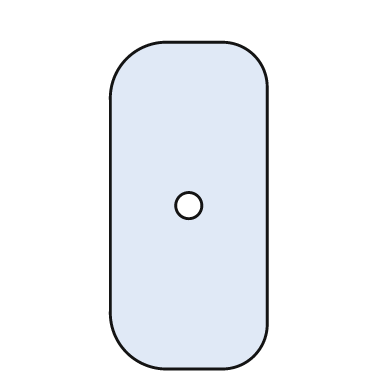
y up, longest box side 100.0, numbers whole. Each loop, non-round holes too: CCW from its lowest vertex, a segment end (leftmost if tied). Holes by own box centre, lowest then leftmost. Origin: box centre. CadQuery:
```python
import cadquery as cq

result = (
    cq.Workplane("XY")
    .moveTo(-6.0, -50.0)
    .lineTo(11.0, -50.0)
    .threePointArc((20.0, -46.0), (24.0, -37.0))
    .lineTo(24.0, 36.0)
    .threePointArc((20.0, 46.0), (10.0, 50.0))
    .lineTo(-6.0, 50.0)
    .threePointArc((-19.0, 45.0), (-24.0, 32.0))
    .lineTo(-24.0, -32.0)
    .threePointArc((-19.0, -45.0), (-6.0, -50.0))
    .close()
    .moveTo(0.0, 0.0)
    .circle(4.0)
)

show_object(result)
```